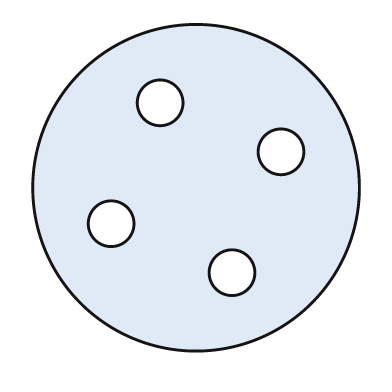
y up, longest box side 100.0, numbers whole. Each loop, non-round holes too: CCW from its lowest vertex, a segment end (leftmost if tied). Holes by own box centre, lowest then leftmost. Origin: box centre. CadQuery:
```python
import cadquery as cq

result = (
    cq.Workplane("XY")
    .moveTo(0.0, 0.0)
    .circle(50.0)
    .moveTo(11.0, -26.0)
    .circle(7.0)
    .moveTo(-26.0, -11.0)
    .circle(7.0)
    .moveTo(26.0, 11.0)
    .circle(7.0)
    .moveTo(-11.0, 26.0)
    .circle(7.0)
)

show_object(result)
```